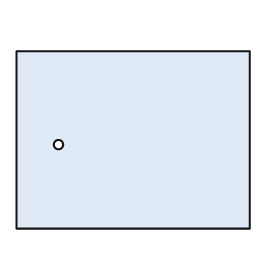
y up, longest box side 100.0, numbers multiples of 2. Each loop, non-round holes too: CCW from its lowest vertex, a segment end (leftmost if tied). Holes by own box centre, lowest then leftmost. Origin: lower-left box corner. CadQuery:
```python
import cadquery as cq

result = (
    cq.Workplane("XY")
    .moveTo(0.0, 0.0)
    .lineTo(100.0, 0.0)
    .lineTo(100.0, 76.0)
    .lineTo(0.0, 76.0)
    .close()
    .moveTo(18.0, 36.0)
    .circle(2.0)
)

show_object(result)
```